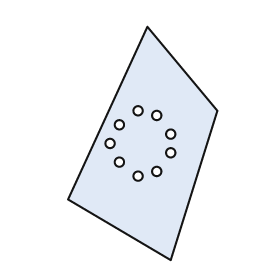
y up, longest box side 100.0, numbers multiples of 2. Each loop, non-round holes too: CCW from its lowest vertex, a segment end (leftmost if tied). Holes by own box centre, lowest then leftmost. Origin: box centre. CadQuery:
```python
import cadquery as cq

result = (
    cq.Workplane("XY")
    .moveTo(12.0, -50.0)
    .lineTo(32.0, 14.0)
    .lineTo(2.0, 50.0)
    .lineTo(-32.0, -24.0)
    .close()
    .moveTo(-2.0, -14.0)
    .circle(2.0)
    .moveTo(6.0, -12.0)
    .circle(2.0)
    .moveTo(-10.0, -8.0)
    .circle(2.0)
    .moveTo(12.0, -4.0)
    .circle(2.0)
    .moveTo(-14.0, 0.0)
    .circle(2.0)
    .moveTo(12.0, 4.0)
    .circle(2.0)
    .moveTo(-10.0, 8.0)
    .circle(2.0)
    .moveTo(6.0, 12.0)
    .circle(2.0)
    .moveTo(-2.0, 14.0)
    .circle(2.0)
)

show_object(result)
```